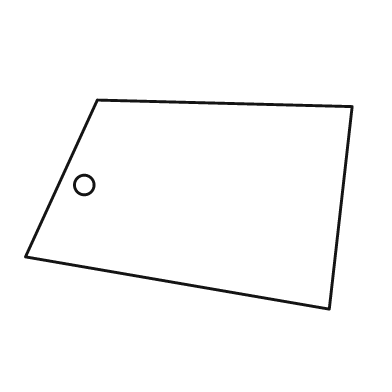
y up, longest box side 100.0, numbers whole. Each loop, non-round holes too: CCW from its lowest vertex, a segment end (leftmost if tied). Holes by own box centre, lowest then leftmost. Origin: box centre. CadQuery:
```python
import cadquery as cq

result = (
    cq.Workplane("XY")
    .moveTo(43.0, -32.0)
    .lineTo(50.0, 30.0)
    .lineTo(-28.0, 32.0)
    .lineTo(-50.0, -16.0)
    .close()
    .moveTo(-32.0, 6.0)
    .circle(3.0)
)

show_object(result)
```